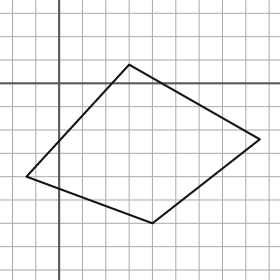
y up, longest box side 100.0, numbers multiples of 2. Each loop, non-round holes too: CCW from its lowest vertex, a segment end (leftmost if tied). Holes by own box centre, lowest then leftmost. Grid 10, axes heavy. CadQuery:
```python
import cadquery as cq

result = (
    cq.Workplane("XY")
    .moveTo(40.0, -60.0)
    .lineTo(86.0, -24.0)
    .lineTo(30.0, 8.0)
    .lineTo(-14.0, -40.0)
    .close()
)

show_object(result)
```